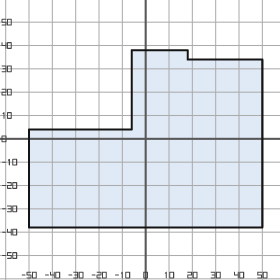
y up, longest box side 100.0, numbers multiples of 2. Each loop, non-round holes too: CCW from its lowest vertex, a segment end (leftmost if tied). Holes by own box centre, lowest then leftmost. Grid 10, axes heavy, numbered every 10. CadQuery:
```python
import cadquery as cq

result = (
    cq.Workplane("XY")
    .moveTo(-50.0, -38.0)
    .lineTo(50.0, -38.0)
    .lineTo(50.0, 34.0)
    .lineTo(18.0, 34.0)
    .lineTo(18.0, 38.0)
    .lineTo(-6.0, 38.0)
    .lineTo(-6.0, 4.0)
    .lineTo(-50.0, 4.0)
    .close()
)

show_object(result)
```